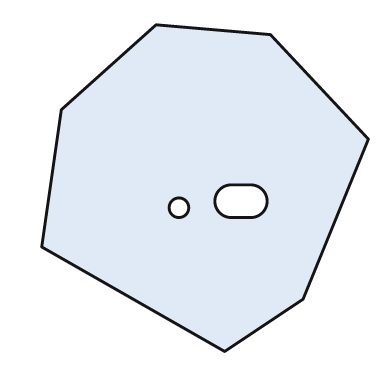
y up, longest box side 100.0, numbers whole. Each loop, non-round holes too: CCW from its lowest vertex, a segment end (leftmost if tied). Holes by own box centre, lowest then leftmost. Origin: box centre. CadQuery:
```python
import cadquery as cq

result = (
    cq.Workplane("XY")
    .moveTo(6.0, -50.0)
    .lineTo(30.0, -34.0)
    .lineTo(50.0, 15.0)
    .lineTo(20.0, 47.0)
    .lineTo(-15.0, 50.0)
    .lineTo(-44.0, 24.0)
    .lineTo(-50.0, -18.0)
    .close()
    .moveTo(-8.0, -6.0)
    .circle(3.0)
    .moveTo(8.0, -9.0)
    .lineTo(14.0, -9.0)
    .threePointArc((19.0, -4.0), (14.0, 1.0))
    .lineTo(8.0, 1.0)
    .threePointArc((3.0, -4.0), (8.0, -9.0))
    .close()
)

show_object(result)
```